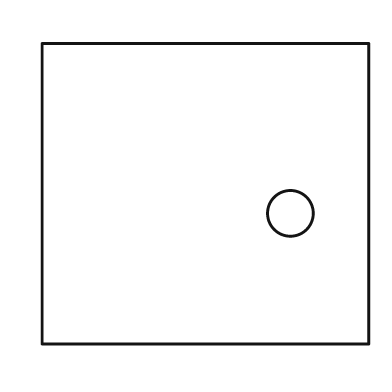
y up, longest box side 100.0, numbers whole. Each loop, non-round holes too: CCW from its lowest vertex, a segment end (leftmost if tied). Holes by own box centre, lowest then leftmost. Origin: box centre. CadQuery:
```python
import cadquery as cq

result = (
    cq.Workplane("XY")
    .moveTo(-50.0, -46.0)
    .lineTo(50.0, -46.0)
    .lineTo(50.0, 46.0)
    .lineTo(-50.0, 46.0)
    .close()
    .moveTo(26.0, -6.0)
    .circle(7.0)
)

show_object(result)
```